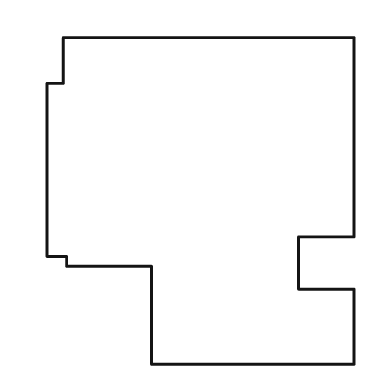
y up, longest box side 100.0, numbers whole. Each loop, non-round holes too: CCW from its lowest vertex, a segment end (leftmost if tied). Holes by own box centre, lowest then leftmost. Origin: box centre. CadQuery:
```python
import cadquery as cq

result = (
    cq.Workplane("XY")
    .moveTo(-15.0, -50.0)
    .lineTo(47.0, -50.0)
    .lineTo(47.0, -27.0)
    .lineTo(30.0, -27.0)
    .lineTo(30.0, -11.0)
    .lineTo(47.0, -11.0)
    .lineTo(47.0, 50.0)
    .lineTo(-42.0, 50.0)
    .lineTo(-42.0, 36.0)
    .lineTo(-47.0, 36.0)
    .lineTo(-47.0, -17.0)
    .lineTo(-41.0, -17.0)
    .lineTo(-41.0, -20.0)
    .lineTo(-15.0, -20.0)
    .close()
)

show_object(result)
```